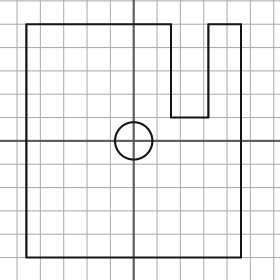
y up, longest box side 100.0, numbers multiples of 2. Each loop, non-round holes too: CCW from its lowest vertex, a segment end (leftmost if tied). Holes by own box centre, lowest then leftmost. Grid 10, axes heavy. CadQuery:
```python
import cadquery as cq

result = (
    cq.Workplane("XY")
    .moveTo(-46.0, -50.0)
    .lineTo(46.0, -50.0)
    .lineTo(46.0, 50.0)
    .lineTo(32.0, 50.0)
    .lineTo(32.0, 10.0)
    .lineTo(16.0, 10.0)
    .lineTo(16.0, 50.0)
    .lineTo(-46.0, 50.0)
    .close()
    .moveTo(0.0, 0.0)
    .circle(8.0)
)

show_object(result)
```